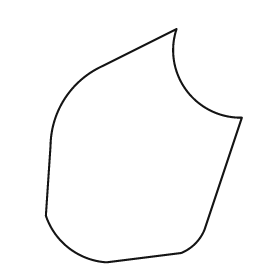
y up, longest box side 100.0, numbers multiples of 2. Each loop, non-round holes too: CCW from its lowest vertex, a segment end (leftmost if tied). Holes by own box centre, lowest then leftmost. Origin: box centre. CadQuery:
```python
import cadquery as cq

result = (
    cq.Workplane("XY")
    .moveTo(-16.0, -50.0)
    .lineTo(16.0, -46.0)
    .threePointArc((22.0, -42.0), (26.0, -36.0))
    .lineTo(42.0, 12.0)
    .threePointArc((18.0, 24.0), (14.0, 50.0))
    .lineTo(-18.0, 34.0)
    .threePointArc((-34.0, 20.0), (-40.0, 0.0))
    .lineTo(-42.0, -30.0)
    .threePointArc((-32.0, -44.0), (-16.0, -50.0))
    .close()
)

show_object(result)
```